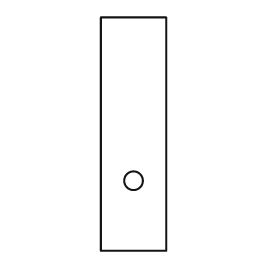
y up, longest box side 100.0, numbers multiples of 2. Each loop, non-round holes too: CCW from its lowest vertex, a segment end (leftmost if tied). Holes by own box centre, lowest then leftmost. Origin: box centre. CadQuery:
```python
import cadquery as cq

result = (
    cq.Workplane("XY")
    .moveTo(-14.0, -50.0)
    .lineTo(14.0, -50.0)
    .lineTo(14.0, 50.0)
    .lineTo(-14.0, 50.0)
    .close()
    .moveTo(0.0, -20.0)
    .circle(4.0)
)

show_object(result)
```